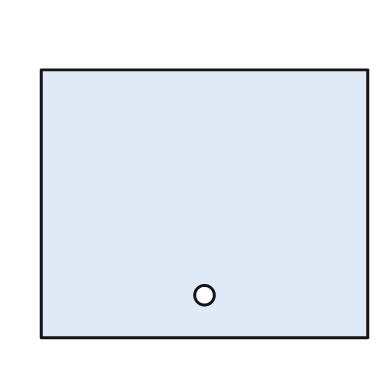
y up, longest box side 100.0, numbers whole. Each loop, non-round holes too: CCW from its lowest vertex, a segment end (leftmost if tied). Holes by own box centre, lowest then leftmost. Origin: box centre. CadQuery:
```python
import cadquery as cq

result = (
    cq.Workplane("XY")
    .moveTo(-50.0, -41.0)
    .lineTo(50.0, -41.0)
    .lineTo(50.0, 41.0)
    .lineTo(-50.0, 41.0)
    .close()
    .moveTo(0.0, -28.0)
    .circle(3.0)
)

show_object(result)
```